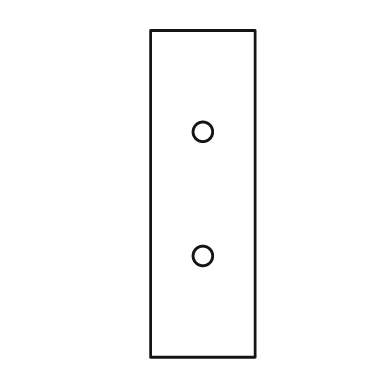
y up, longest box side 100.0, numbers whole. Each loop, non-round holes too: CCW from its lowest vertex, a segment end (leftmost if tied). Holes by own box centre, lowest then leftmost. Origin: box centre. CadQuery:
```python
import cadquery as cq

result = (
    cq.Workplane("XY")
    .moveTo(-16.0, -50.0)
    .lineTo(16.0, -50.0)
    .lineTo(16.0, 50.0)
    .lineTo(-16.0, 50.0)
    .close()
    .moveTo(0.0, -19.0)
    .circle(3.0)
    .moveTo(0.0, 19.0)
    .circle(3.0)
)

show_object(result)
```